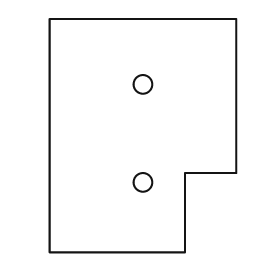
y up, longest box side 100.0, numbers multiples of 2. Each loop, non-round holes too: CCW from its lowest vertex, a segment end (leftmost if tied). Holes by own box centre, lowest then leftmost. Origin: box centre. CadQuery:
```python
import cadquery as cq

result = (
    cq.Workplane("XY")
    .moveTo(-40.0, -50.0)
    .lineTo(18.0, -50.0)
    .lineTo(18.0, -16.0)
    .lineTo(40.0, -16.0)
    .lineTo(40.0, 50.0)
    .lineTo(-40.0, 50.0)
    .close()
    .moveTo(0.0, -20.0)
    .circle(4.0)
    .moveTo(0.0, 22.0)
    .circle(4.0)
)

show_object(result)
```